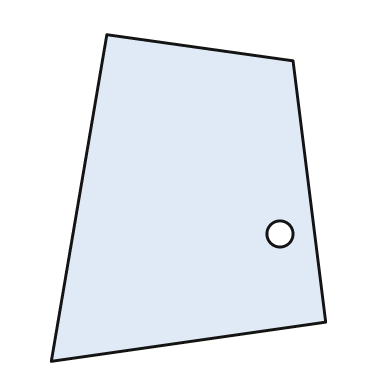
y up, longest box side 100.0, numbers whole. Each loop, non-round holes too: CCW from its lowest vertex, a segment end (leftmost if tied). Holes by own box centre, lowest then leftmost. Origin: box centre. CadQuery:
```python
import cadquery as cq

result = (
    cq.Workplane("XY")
    .moveTo(-42.0, -50.0)
    .lineTo(42.0, -38.0)
    .lineTo(32.0, 42.0)
    .lineTo(-25.0, 50.0)
    .close()
    .moveTo(28.0, -11.0)
    .circle(4.0)
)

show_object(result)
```